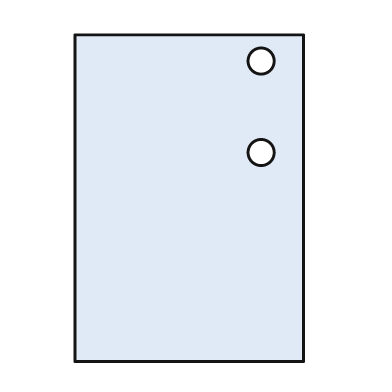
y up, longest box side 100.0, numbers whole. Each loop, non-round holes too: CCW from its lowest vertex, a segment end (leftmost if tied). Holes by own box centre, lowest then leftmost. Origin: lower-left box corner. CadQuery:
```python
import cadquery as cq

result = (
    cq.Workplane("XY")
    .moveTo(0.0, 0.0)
    .lineTo(70.0, 0.0)
    .lineTo(70.0, 100.0)
    .lineTo(0.0, 100.0)
    .close()
    .moveTo(57.0, 64.0)
    .circle(4.0)
    .moveTo(57.0, 92.0)
    .circle(4.0)
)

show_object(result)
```